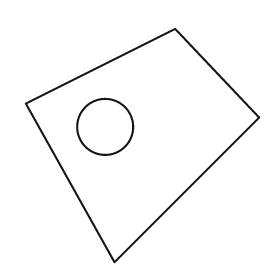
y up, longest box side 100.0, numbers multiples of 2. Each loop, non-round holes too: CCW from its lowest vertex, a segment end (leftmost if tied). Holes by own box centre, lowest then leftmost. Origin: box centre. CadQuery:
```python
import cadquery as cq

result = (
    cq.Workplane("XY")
    .moveTo(-12.0, -50.0)
    .lineTo(50.0, 12.0)
    .lineTo(14.0, 50.0)
    .lineTo(-50.0, 18.0)
    .close()
    .moveTo(-16.0, 8.0)
    .circle(12.0)
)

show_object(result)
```